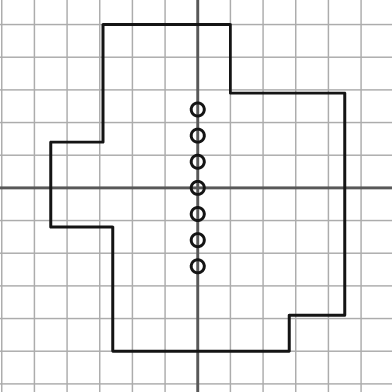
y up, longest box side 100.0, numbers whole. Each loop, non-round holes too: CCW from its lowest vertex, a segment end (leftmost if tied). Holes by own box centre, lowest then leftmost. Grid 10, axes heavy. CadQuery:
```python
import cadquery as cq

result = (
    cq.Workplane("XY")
    .moveTo(-26.0, -50.0)
    .lineTo(28.0, -50.0)
    .lineTo(28.0, -39.0)
    .lineTo(45.0, -39.0)
    .lineTo(45.0, 29.0)
    .lineTo(10.0, 29.0)
    .lineTo(10.0, 50.0)
    .lineTo(-29.0, 50.0)
    .lineTo(-29.0, 14.0)
    .lineTo(-45.0, 14.0)
    .lineTo(-45.0, -12.0)
    .lineTo(-26.0, -12.0)
    .close()
    .moveTo(0.0, -24.0)
    .circle(2.0)
    .moveTo(0.0, -16.0)
    .circle(2.0)
    .moveTo(0.0, -8.0)
    .circle(2.0)
    .moveTo(0.0, 0.0)
    .circle(2.0)
    .moveTo(0.0, 8.0)
    .circle(2.0)
    .moveTo(0.0, 16.0)
    .circle(2.0)
    .moveTo(0.0, 24.0)
    .circle(2.0)
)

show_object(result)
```